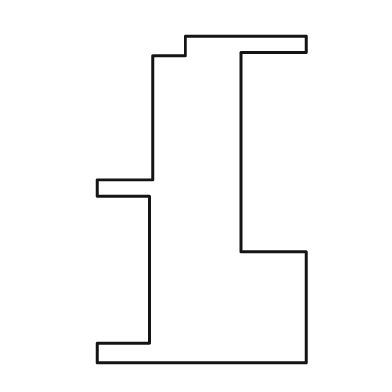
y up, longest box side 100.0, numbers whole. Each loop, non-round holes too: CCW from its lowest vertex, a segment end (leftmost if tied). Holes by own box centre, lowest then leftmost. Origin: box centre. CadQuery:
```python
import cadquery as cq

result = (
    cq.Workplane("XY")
    .moveTo(-32.0, -50.0)
    .lineTo(32.0, -50.0)
    .lineTo(32.0, -16.0)
    .lineTo(12.0, -16.0)
    .lineTo(12.0, 45.0)
    .lineTo(32.0, 45.0)
    .lineTo(32.0, 50.0)
    .lineTo(-5.0, 50.0)
    .lineTo(-5.0, 44.0)
    .lineTo(-15.0, 44.0)
    .lineTo(-15.0, 6.0)
    .lineTo(-32.0, 6.0)
    .lineTo(-32.0, 1.0)
    .lineTo(-16.0, 1.0)
    .lineTo(-16.0, -44.0)
    .lineTo(-32.0, -44.0)
    .close()
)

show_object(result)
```